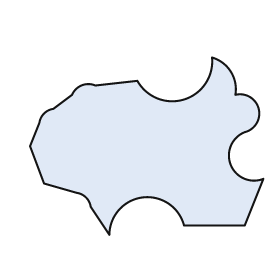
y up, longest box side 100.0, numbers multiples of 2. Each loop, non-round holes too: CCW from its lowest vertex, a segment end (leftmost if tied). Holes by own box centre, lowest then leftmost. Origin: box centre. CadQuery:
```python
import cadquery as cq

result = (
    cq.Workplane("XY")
    .moveTo(-16.0, -38.0)
    .threePointArc((-2.0, -22.0), (16.0, -34.0))
    .lineTo(42.0, -34.0)
    .lineTo(50.0, -14.0)
    .threePointArc((36.0, -8.0), (42.0, 6.0))
    .threePointArc((48.0, 16.0), (38.0, 22.0))
    .threePointArc((36.0, 32.0), (28.0, 38.0))
    .threePointArc((16.0, 20.0), (-4.0, 28.0))
    .lineTo(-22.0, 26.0)
    .threePointArc((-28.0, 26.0), (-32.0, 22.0))
    .lineTo(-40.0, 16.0)
    .threePointArc((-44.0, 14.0), (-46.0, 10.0))
    .lineTo(-50.0, 0.0)
    .lineTo(-44.0, -16.0)
    .lineTo(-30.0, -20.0)
    .threePointArc((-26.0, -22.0), (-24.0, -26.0))
    .close()
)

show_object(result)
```